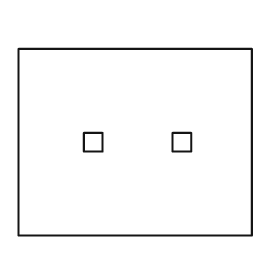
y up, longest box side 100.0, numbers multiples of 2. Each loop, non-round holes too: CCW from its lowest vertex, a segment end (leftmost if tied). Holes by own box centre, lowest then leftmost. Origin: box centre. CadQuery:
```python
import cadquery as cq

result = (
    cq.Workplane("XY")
    .moveTo(-50.0, -40.0)
    .lineTo(50.0, -40.0)
    .lineTo(50.0, 40.0)
    .lineTo(-50.0, 40.0)
    .close()
    .moveTo(-22.0, -4.0)
    .lineTo(-14.0, -4.0)
    .lineTo(-14.0, 4.0)
    .lineTo(-22.0, 4.0)
    .close()
    .moveTo(16.0, -4.0)
    .lineTo(24.0, -4.0)
    .lineTo(24.0, 4.0)
    .lineTo(16.0, 4.0)
    .close()
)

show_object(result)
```